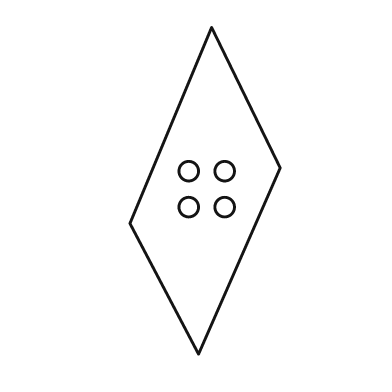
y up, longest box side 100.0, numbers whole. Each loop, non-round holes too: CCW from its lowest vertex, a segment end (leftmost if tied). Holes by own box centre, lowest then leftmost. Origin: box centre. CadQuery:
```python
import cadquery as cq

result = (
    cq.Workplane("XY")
    .moveTo(-2.0, -50.0)
    .lineTo(23.0, 7.0)
    .lineTo(2.0, 50.0)
    .lineTo(-23.0, -10.0)
    .close()
    .moveTo(-5.0, -5.0)
    .circle(3.0)
    .moveTo(6.0, -5.0)
    .circle(3.0)
    .moveTo(-5.0, 6.0)
    .circle(3.0)
    .moveTo(6.0, 6.0)
    .circle(3.0)
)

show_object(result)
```